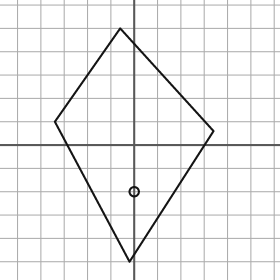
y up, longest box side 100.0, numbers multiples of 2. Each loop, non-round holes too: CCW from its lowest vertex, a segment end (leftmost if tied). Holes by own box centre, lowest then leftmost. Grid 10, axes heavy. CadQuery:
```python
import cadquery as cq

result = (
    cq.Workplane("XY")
    .moveTo(-2.0, -50.0)
    .lineTo(34.0, 6.0)
    .lineTo(-6.0, 50.0)
    .lineTo(-34.0, 10.0)
    .close()
    .moveTo(0.0, -20.0)
    .circle(2.0)
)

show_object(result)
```